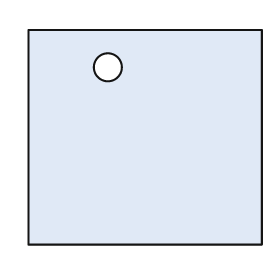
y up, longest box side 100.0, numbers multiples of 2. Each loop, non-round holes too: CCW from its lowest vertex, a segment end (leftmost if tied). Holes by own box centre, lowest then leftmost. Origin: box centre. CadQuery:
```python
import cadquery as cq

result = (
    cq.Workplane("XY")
    .moveTo(-50.0, -46.0)
    .lineTo(50.0, -46.0)
    .lineTo(50.0, 46.0)
    .lineTo(-50.0, 46.0)
    .close()
    .moveTo(-16.0, 30.0)
    .circle(6.0)
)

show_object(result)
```